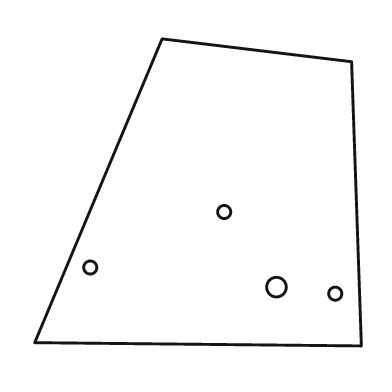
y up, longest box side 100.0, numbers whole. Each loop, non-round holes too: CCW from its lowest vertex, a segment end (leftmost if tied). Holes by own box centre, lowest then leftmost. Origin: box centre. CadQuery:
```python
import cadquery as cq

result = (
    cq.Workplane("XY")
    .moveTo(50.0, -47.0)
    .lineTo(47.0, 40.0)
    .lineTo(-11.0, 47.0)
    .lineTo(-50.0, -46.0)
    .close()
    .moveTo(42.0, -31.0)
    .circle(2.0)
    .moveTo(24.0, -29.0)
    .circle(3.0)
    .moveTo(-33.0, -23.0)
    .circle(2.0)
    .moveTo(8.0, -6.0)
    .circle(2.0)
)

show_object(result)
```